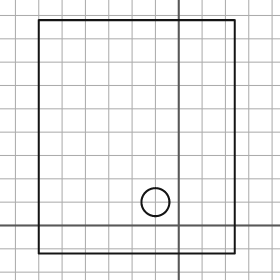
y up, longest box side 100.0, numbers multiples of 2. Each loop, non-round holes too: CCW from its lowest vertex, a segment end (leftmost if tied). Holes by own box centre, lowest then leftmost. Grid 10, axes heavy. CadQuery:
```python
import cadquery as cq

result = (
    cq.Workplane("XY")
    .moveTo(-60.0, -12.0)
    .lineTo(24.0, -12.0)
    .lineTo(24.0, 88.0)
    .lineTo(-60.0, 88.0)
    .close()
    .moveTo(-10.0, 10.0)
    .circle(6.0)
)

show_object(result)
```